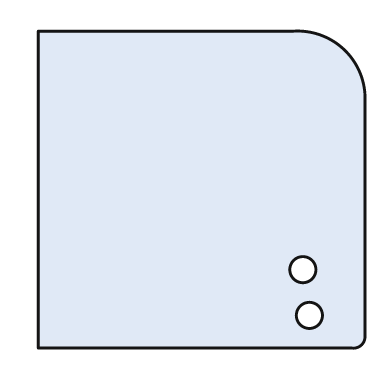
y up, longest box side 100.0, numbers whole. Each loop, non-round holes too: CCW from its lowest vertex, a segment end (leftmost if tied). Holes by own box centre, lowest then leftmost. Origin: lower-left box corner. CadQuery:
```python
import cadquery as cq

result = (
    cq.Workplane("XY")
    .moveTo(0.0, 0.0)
    .lineTo(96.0, 0.0)
    .threePointArc((99.0, 1.0), (100.0, 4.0))
    .lineTo(100.0, 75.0)
    .threePointArc((94.0, 91.0), (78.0, 97.0))
    .lineTo(0.0, 97.0)
    .close()
    .moveTo(83.0, 10.0)
    .circle(4.0)
    .moveTo(81.0, 24.0)
    .circle(4.0)
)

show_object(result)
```